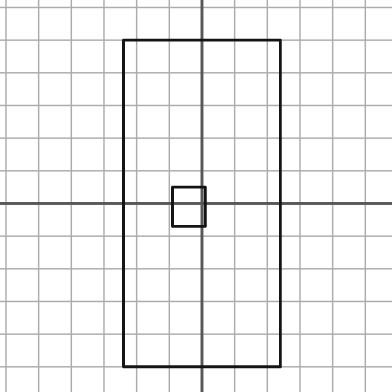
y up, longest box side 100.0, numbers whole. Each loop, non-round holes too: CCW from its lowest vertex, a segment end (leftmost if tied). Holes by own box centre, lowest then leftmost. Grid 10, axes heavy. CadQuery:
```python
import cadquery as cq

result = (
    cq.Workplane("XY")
    .moveTo(-24.0, -50.0)
    .lineTo(24.0, -50.0)
    .lineTo(24.0, 50.0)
    .lineTo(-24.0, 50.0)
    .close()
    .moveTo(-9.0, -7.0)
    .lineTo(1.0, -7.0)
    .lineTo(1.0, 5.0)
    .lineTo(-9.0, 5.0)
    .close()
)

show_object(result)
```